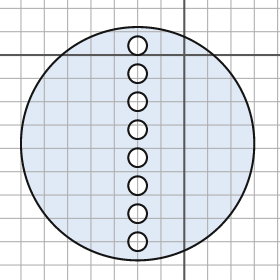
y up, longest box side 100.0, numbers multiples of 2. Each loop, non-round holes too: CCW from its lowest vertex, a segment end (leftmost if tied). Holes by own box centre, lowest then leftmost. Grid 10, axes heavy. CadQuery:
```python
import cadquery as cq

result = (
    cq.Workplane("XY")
    .moveTo(-20.0, -38.0)
    .circle(50.0)
    .moveTo(-20.0, -80.0)
    .circle(4.0)
    .moveTo(-20.0, -68.0)
    .circle(4.0)
    .moveTo(-20.0, -56.0)
    .circle(4.0)
    .moveTo(-20.0, -44.0)
    .circle(4.0)
    .moveTo(-20.0, -32.0)
    .circle(4.0)
    .moveTo(-20.0, -20.0)
    .circle(4.0)
    .moveTo(-20.0, -8.0)
    .circle(4.0)
    .moveTo(-20.0, 4.0)
    .circle(4.0)
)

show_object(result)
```